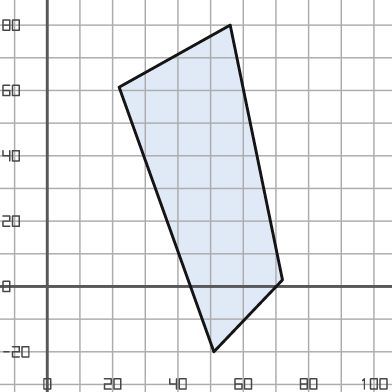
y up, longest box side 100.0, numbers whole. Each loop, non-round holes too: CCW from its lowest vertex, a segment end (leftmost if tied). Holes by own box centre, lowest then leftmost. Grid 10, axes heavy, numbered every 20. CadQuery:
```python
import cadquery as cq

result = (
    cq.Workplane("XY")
    .moveTo(51.0, -20.0)
    .lineTo(72.0, 2.0)
    .lineTo(56.0, 80.0)
    .lineTo(22.0, 61.0)
    .close()
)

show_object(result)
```